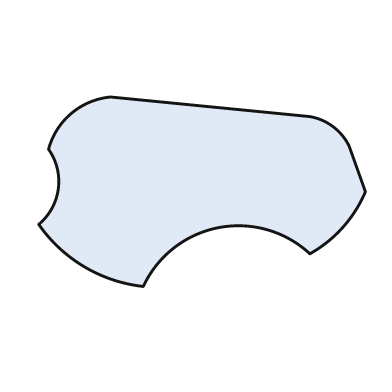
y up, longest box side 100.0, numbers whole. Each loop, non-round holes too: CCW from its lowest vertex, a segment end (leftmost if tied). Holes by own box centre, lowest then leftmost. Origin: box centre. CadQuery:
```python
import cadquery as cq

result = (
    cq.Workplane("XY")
    .moveTo(-18.0, -29.0)
    .threePointArc((5.0, -11.0), (33.0, -19.0))
    .threePointArc((43.0, -11.0), (50.0, 0.0))
    .lineTo(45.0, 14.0)
    .threePointArc((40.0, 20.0), (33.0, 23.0))
    .lineTo(-28.0, 29.0)
    .threePointArc((-40.0, 24.0), (-47.0, 13.0))
    .threePointArc((-44.0, 1.0), (-50.0, -10.0))
    .threePointArc((-36.0, -23.0), (-18.0, -29.0))
    .close()
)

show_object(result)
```